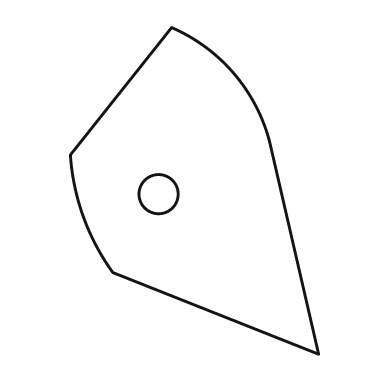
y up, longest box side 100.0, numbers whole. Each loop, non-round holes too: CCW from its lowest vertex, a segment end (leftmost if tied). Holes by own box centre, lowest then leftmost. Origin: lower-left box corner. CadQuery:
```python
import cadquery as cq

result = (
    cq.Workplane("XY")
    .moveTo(76.0, 0.0)
    .lineTo(61.0, 65.0)
    .threePointArc((50.0, 86.0), (31.0, 100.0))
    .lineTo(0.0, 61.0)
    .threePointArc((4.0, 42.0), (13.0, 25.0))
    .close()
    .moveTo(27.0, 49.0)
    .circle(6.0)
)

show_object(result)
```